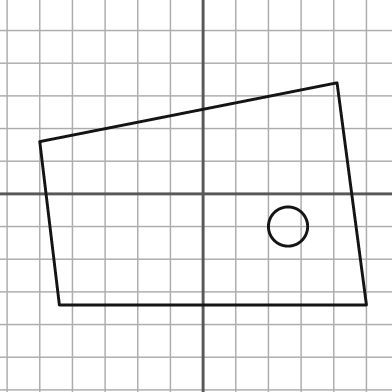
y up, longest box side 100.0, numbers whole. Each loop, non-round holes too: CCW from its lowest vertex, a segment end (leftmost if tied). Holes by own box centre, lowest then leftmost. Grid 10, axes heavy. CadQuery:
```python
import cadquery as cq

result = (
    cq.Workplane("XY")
    .moveTo(-44.0, -34.0)
    .lineTo(50.0, -34.0)
    .lineTo(41.0, 34.0)
    .lineTo(-50.0, 16.0)
    .close()
    .moveTo(26.0, -10.0)
    .circle(6.0)
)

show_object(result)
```